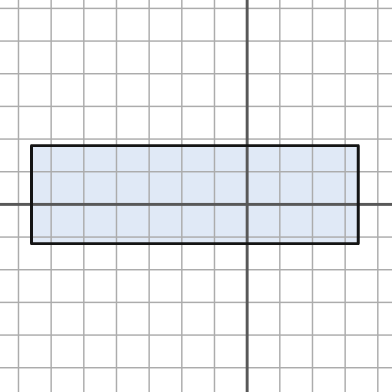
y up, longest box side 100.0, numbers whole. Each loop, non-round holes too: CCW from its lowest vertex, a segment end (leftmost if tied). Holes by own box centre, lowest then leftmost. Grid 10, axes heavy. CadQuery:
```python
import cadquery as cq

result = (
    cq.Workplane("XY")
    .moveTo(-66.0, -12.0)
    .lineTo(34.0, -12.0)
    .lineTo(34.0, 18.0)
    .lineTo(-66.0, 18.0)
    .close()
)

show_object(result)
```